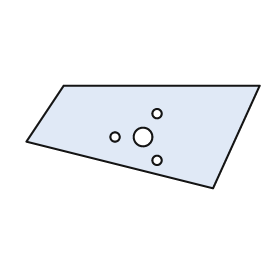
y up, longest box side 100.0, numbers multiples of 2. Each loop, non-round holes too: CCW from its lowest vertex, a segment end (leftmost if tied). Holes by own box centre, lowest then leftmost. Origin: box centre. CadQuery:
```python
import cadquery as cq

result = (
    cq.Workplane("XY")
    .moveTo(30.0, -22.0)
    .lineTo(50.0, 22.0)
    .lineTo(-34.0, 22.0)
    .lineTo(-50.0, -2.0)
    .close()
    .moveTo(6.0, -10.0)
    .circle(2.0)
    .moveTo(-12.0, 0.0)
    .circle(2.0)
    .moveTo(0.0, 0.0)
    .circle(4.0)
    .moveTo(6.0, 10.0)
    .circle(2.0)
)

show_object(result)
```